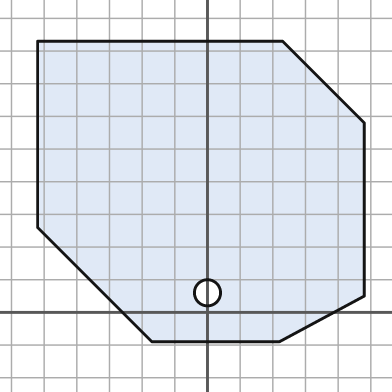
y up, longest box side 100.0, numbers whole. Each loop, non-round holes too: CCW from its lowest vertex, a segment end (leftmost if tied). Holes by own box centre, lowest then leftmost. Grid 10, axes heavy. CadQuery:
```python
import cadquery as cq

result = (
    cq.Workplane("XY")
    .moveTo(-17.0, -9.0)
    .lineTo(22.0, -9.0)
    .lineTo(48.0, 5.0)
    .lineTo(48.0, 58.0)
    .lineTo(23.0, 83.0)
    .lineTo(-52.0, 83.0)
    .lineTo(-52.0, 26.0)
    .close()
    .moveTo(0.0, 6.0)
    .circle(4.0)
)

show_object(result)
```